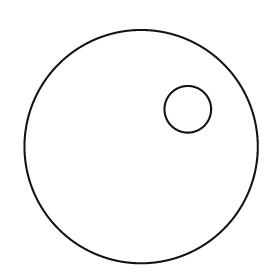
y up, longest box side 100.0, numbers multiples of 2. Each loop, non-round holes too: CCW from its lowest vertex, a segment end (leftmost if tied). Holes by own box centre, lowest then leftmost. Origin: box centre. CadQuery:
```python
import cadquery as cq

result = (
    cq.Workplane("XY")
    .moveTo(0.0, 0.0)
    .circle(50.0)
    .moveTo(20.0, 16.0)
    .circle(10.0)
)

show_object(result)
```